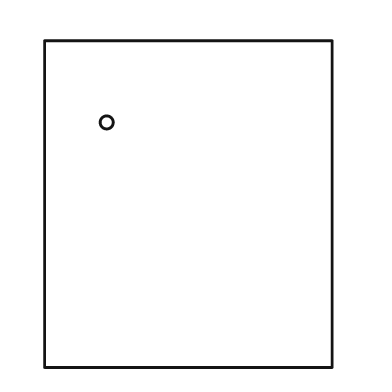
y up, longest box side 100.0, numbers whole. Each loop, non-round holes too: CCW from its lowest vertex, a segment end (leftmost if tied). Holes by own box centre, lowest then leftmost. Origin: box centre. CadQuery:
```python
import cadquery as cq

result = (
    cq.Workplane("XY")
    .moveTo(-44.0, -50.0)
    .lineTo(44.0, -50.0)
    .lineTo(44.0, 50.0)
    .lineTo(-44.0, 50.0)
    .close()
    .moveTo(-25.0, 25.0)
    .circle(2.0)
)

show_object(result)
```